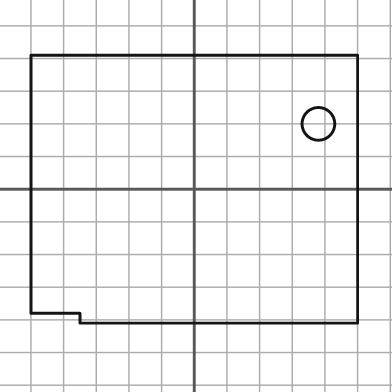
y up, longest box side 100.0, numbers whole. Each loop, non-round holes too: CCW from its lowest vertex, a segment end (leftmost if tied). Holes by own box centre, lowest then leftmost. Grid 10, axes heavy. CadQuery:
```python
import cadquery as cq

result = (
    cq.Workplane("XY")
    .moveTo(-35.0, -41.0)
    .lineTo(50.0, -41.0)
    .lineTo(50.0, 41.0)
    .lineTo(-50.0, 41.0)
    .lineTo(-50.0, -38.0)
    .lineTo(-35.0, -38.0)
    .close()
    .moveTo(38.0, 20.0)
    .circle(5.0)
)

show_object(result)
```